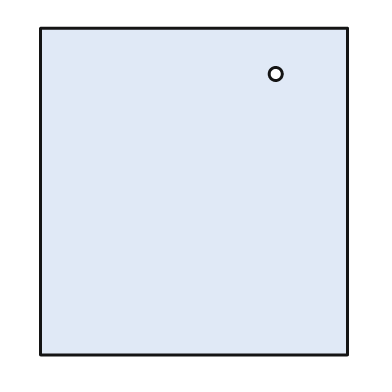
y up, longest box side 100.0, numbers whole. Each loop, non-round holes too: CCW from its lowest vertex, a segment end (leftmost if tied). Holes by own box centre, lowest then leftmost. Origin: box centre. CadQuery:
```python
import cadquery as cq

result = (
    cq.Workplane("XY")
    .moveTo(-47.0, -50.0)
    .lineTo(47.0, -50.0)
    .lineTo(47.0, 50.0)
    .lineTo(-47.0, 50.0)
    .close()
    .moveTo(25.0, 36.0)
    .circle(2.0)
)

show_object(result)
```